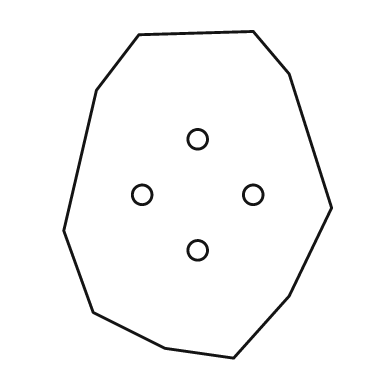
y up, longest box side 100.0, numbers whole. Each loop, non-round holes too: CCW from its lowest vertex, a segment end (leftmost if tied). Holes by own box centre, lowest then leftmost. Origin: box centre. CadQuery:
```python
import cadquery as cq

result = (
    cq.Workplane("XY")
    .moveTo(11.0, -50.0)
    .lineTo(28.0, -31.0)
    .lineTo(41.0, -4.0)
    .lineTo(28.0, 37.0)
    .lineTo(17.0, 50.0)
    .lineTo(-18.0, 49.0)
    .lineTo(-31.0, 32.0)
    .lineTo(-41.0, -11.0)
    .lineTo(-32.0, -36.0)
    .lineTo(-10.0, -47.0)
    .close()
    .moveTo(0.0, -17.0)
    .circle(3.0)
    .moveTo(-17.0, 0.0)
    .circle(3.0)
    .moveTo(17.0, 0.0)
    .circle(3.0)
    .moveTo(0.0, 17.0)
    .circle(3.0)
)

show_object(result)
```